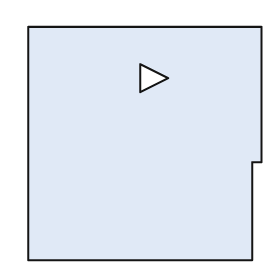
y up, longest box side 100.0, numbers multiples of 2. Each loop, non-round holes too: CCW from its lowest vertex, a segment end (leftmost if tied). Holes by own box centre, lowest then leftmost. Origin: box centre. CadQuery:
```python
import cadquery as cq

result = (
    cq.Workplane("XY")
    .moveTo(-50.0, -50.0)
    .lineTo(46.0, -50.0)
    .lineTo(46.0, -8.0)
    .lineTo(50.0, -8.0)
    .lineTo(50.0, 50.0)
    .lineTo(-50.0, 50.0)
    .close()
    .moveTo(-2.0, 22.0)
    .lineTo(10.0, 28.0)
    .lineTo(-2.0, 34.0)
    .close()
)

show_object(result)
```